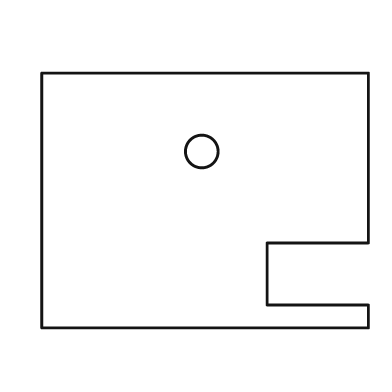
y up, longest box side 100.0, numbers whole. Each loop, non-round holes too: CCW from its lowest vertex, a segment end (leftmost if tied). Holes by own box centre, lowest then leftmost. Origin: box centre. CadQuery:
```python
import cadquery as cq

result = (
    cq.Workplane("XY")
    .moveTo(-50.0, -39.0)
    .lineTo(50.0, -39.0)
    .lineTo(50.0, -32.0)
    .lineTo(19.0, -32.0)
    .lineTo(19.0, -13.0)
    .lineTo(50.0, -13.0)
    .lineTo(50.0, 39.0)
    .lineTo(-50.0, 39.0)
    .close()
    .moveTo(-1.0, 15.0)
    .circle(5.0)
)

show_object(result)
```